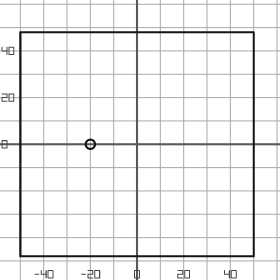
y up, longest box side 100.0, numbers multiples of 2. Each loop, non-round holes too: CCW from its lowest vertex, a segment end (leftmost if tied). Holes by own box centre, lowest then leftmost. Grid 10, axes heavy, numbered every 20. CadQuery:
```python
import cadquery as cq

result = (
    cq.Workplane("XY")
    .moveTo(-50.0, -48.0)
    .lineTo(50.0, -48.0)
    .lineTo(50.0, 48.0)
    .lineTo(-50.0, 48.0)
    .close()
    .moveTo(-20.0, 0.0)
    .circle(2.0)
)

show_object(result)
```